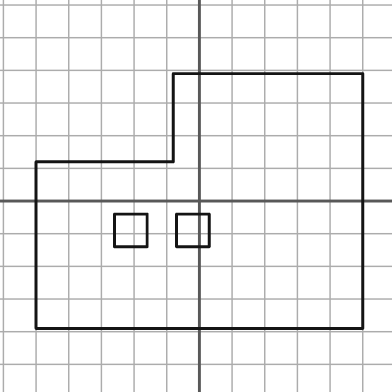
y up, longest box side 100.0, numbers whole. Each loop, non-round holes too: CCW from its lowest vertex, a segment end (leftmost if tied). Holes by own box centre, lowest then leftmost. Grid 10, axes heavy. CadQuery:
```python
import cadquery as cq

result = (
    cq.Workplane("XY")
    .moveTo(-50.0, -39.0)
    .lineTo(50.0, -39.0)
    .lineTo(50.0, 39.0)
    .lineTo(-8.0, 39.0)
    .lineTo(-8.0, 12.0)
    .lineTo(-50.0, 12.0)
    .close()
    .moveTo(-26.0, -14.0)
    .lineTo(-16.0, -14.0)
    .lineTo(-16.0, -4.0)
    .lineTo(-26.0, -4.0)
    .close()
    .moveTo(-7.0, -14.0)
    .lineTo(3.0, -14.0)
    .lineTo(3.0, -4.0)
    .lineTo(-7.0, -4.0)
    .close()
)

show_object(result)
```